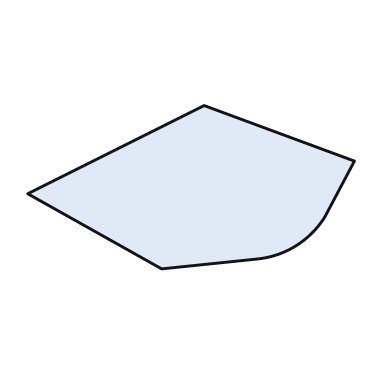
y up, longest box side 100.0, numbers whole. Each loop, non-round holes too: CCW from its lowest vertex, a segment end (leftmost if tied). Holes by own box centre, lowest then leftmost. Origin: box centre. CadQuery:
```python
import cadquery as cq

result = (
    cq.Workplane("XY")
    .moveTo(-9.0, -25.0)
    .lineTo(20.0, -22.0)
    .threePointArc((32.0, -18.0), (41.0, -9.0))
    .lineTo(50.0, 8.0)
    .lineTo(4.0, 25.0)
    .lineTo(-50.0, -2.0)
    .close()
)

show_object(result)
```